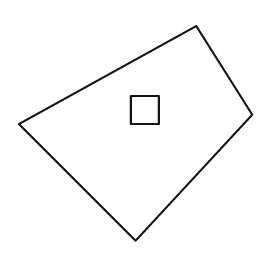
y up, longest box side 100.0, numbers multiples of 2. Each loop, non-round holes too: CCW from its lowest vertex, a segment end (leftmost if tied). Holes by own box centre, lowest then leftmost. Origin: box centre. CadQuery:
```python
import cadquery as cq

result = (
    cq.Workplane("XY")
    .moveTo(0.0, -46.0)
    .lineTo(50.0, 8.0)
    .lineTo(26.0, 46.0)
    .lineTo(-50.0, 4.0)
    .close()
    .moveTo(-2.0, 4.0)
    .lineTo(10.0, 4.0)
    .lineTo(10.0, 16.0)
    .lineTo(-2.0, 16.0)
    .close()
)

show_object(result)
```